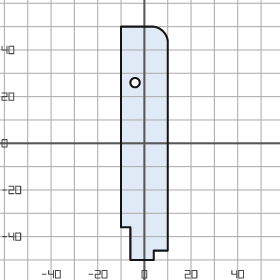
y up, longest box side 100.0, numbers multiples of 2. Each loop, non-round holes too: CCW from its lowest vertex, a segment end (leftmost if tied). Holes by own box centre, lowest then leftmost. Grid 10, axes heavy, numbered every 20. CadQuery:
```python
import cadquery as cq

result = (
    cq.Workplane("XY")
    .moveTo(-6.0, -50.0)
    .lineTo(4.0, -50.0)
    .lineTo(4.0, -46.0)
    .lineTo(10.0, -46.0)
    .lineTo(10.0, 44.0)
    .threePointArc((8.0, 48.0), (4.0, 50.0))
    .lineTo(-10.0, 50.0)
    .lineTo(-10.0, -36.0)
    .lineTo(-6.0, -36.0)
    .close()
    .moveTo(-4.0, 26.0)
    .circle(2.0)
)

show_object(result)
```